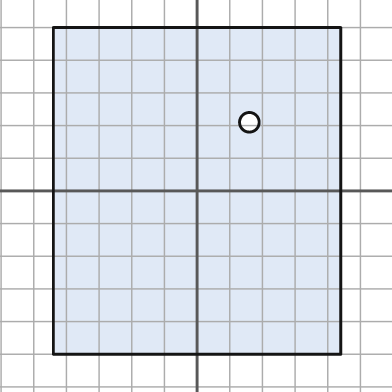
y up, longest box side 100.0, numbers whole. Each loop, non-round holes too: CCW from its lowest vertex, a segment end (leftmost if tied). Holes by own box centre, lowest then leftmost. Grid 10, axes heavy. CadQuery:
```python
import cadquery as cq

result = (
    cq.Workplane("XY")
    .moveTo(-44.0, -50.0)
    .lineTo(44.0, -50.0)
    .lineTo(44.0, 50.0)
    .lineTo(-44.0, 50.0)
    .close()
    .moveTo(16.0, 21.0)
    .circle(3.0)
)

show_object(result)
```